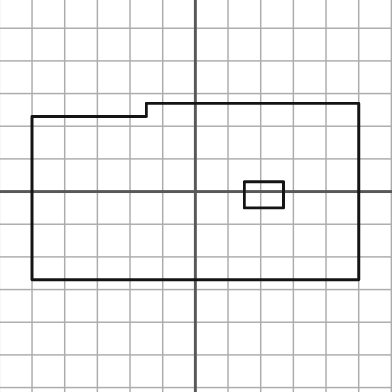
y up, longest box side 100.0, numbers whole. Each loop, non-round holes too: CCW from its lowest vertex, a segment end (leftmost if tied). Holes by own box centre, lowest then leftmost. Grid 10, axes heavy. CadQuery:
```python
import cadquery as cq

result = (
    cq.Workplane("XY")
    .moveTo(-50.0, -27.0)
    .lineTo(50.0, -27.0)
    .lineTo(50.0, 27.0)
    .lineTo(-15.0, 27.0)
    .lineTo(-15.0, 23.0)
    .lineTo(-50.0, 23.0)
    .close()
    .moveTo(15.0, -5.0)
    .lineTo(27.0, -5.0)
    .lineTo(27.0, 3.0)
    .lineTo(15.0, 3.0)
    .close()
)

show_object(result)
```